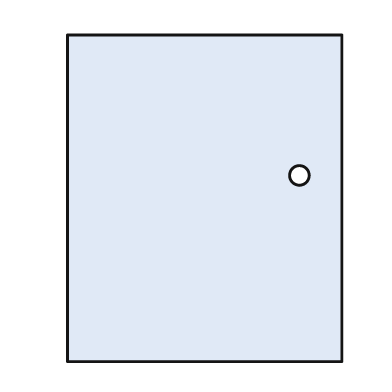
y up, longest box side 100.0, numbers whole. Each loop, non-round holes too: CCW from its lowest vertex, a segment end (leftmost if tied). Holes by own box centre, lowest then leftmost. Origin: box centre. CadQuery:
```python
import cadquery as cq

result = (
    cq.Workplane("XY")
    .moveTo(-42.0, -50.0)
    .lineTo(42.0, -50.0)
    .lineTo(42.0, 50.0)
    .lineTo(-42.0, 50.0)
    .close()
    .moveTo(29.0, 7.0)
    .circle(3.0)
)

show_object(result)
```